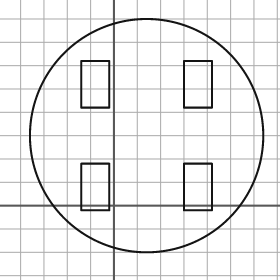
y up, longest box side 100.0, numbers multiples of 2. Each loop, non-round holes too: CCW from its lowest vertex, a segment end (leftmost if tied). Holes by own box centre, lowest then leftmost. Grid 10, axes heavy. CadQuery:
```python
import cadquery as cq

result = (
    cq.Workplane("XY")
    .moveTo(14.0, 30.0)
    .circle(50.0)
    .moveTo(-14.0, -2.0)
    .lineTo(-2.0, -2.0)
    .lineTo(-2.0, 18.0)
    .lineTo(-14.0, 18.0)
    .close()
    .moveTo(30.0, -2.0)
    .lineTo(42.0, -2.0)
    .lineTo(42.0, 18.0)
    .lineTo(30.0, 18.0)
    .close()
    .moveTo(-14.0, 42.0)
    .lineTo(-2.0, 42.0)
    .lineTo(-2.0, 62.0)
    .lineTo(-14.0, 62.0)
    .close()
    .moveTo(30.0, 42.0)
    .lineTo(42.0, 42.0)
    .lineTo(42.0, 62.0)
    .lineTo(30.0, 62.0)
    .close()
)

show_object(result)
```